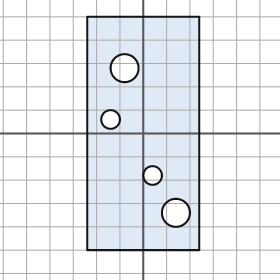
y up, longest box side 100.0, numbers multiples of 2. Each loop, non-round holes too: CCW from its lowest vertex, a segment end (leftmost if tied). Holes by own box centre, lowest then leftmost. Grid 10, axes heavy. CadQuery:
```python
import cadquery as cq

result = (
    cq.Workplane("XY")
    .moveTo(-24.0, -50.0)
    .lineTo(24.0, -50.0)
    .lineTo(24.0, 50.0)
    .lineTo(-24.0, 50.0)
    .close()
    .moveTo(14.0, -34.0)
    .circle(6.0)
    .moveTo(4.0, -18.0)
    .circle(4.0)
    .moveTo(-14.0, 6.0)
    .circle(4.0)
    .moveTo(-8.0, 28.0)
    .circle(6.0)
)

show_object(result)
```